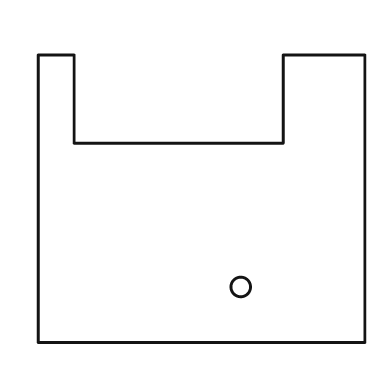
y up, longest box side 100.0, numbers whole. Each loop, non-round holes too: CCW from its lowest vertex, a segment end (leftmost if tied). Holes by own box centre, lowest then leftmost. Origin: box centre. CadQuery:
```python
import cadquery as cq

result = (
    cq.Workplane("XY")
    .moveTo(-50.0, -44.0)
    .lineTo(50.0, -44.0)
    .lineTo(50.0, 44.0)
    .lineTo(25.0, 44.0)
    .lineTo(25.0, 17.0)
    .lineTo(-39.0, 17.0)
    .lineTo(-39.0, 44.0)
    .lineTo(-50.0, 44.0)
    .close()
    .moveTo(12.0, -27.0)
    .circle(3.0)
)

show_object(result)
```